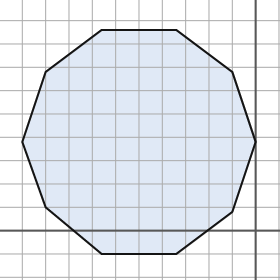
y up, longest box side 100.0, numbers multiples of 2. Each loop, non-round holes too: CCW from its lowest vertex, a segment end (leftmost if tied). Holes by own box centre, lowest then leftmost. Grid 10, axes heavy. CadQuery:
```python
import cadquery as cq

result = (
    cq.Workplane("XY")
    .moveTo(-66.0, -10.0)
    .lineTo(-34.0, -10.0)
    .lineTo(-10.0, 8.0)
    .lineTo(0.0, 38.0)
    .lineTo(-10.0, 68.0)
    .lineTo(-34.0, 86.0)
    .lineTo(-66.0, 86.0)
    .lineTo(-90.0, 68.0)
    .lineTo(-100.0, 38.0)
    .lineTo(-90.0, 10.0)
    .close()
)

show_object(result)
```